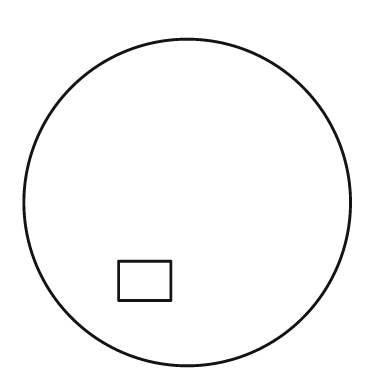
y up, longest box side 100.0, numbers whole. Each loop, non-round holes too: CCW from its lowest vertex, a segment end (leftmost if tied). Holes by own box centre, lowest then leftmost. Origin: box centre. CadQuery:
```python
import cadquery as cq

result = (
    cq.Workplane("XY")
    .moveTo(0.0, 0.0)
    .circle(50.0)
    .moveTo(-21.0, -30.0)
    .lineTo(-5.0, -30.0)
    .lineTo(-5.0, -18.0)
    .lineTo(-21.0, -18.0)
    .close()
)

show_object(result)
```